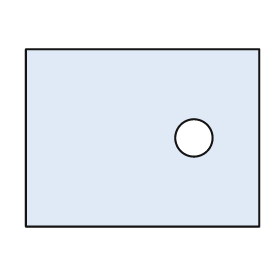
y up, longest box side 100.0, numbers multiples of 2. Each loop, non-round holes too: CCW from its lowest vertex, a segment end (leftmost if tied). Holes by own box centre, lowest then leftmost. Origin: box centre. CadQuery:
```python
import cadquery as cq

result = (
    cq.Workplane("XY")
    .moveTo(-50.0, -38.0)
    .lineTo(50.0, -38.0)
    .lineTo(50.0, 38.0)
    .lineTo(-50.0, 38.0)
    .close()
    .moveTo(22.0, 0.0)
    .circle(8.0)
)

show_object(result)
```